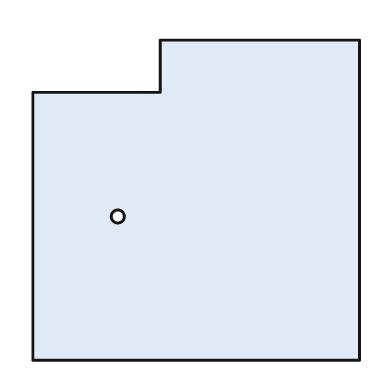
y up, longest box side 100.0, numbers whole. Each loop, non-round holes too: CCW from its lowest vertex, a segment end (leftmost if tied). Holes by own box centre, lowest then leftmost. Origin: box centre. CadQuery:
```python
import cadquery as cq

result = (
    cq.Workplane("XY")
    .moveTo(-50.0, -49.0)
    .lineTo(50.0, -49.0)
    .lineTo(50.0, 49.0)
    .lineTo(-11.0, 49.0)
    .lineTo(-11.0, 33.0)
    .lineTo(-50.0, 33.0)
    .close()
    .moveTo(-24.0, -5.0)
    .circle(2.0)
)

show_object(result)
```